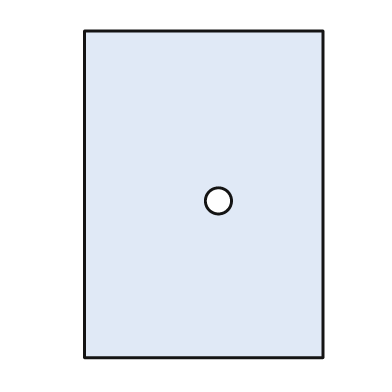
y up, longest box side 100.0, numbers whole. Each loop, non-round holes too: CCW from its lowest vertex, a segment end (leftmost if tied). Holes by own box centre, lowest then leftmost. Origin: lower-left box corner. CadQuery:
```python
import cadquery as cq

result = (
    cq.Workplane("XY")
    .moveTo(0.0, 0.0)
    .lineTo(73.0, 0.0)
    .lineTo(73.0, 100.0)
    .lineTo(0.0, 100.0)
    .close()
    .moveTo(41.0, 48.0)
    .circle(4.0)
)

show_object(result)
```